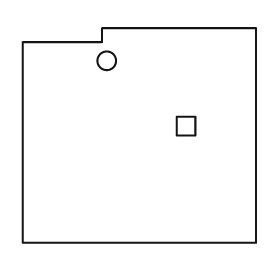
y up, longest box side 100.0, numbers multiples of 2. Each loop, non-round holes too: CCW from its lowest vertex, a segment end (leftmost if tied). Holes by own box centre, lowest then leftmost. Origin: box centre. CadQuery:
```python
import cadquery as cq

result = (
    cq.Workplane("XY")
    .moveTo(-50.0, -46.0)
    .lineTo(50.0, -46.0)
    .lineTo(50.0, 46.0)
    .lineTo(-16.0, 46.0)
    .lineTo(-16.0, 40.0)
    .lineTo(-50.0, 40.0)
    .close()
    .moveTo(16.0, 0.0)
    .lineTo(24.0, 0.0)
    .lineTo(24.0, 8.0)
    .lineTo(16.0, 8.0)
    .close()
    .moveTo(-14.0, 32.0)
    .circle(4.0)
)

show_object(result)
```